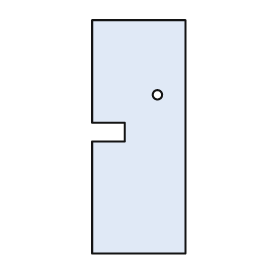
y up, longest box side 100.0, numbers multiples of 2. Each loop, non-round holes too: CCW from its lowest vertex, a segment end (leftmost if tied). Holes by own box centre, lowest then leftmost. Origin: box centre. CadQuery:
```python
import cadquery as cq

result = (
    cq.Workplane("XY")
    .moveTo(-20.0, -50.0)
    .lineTo(20.0, -50.0)
    .lineTo(20.0, 50.0)
    .lineTo(-20.0, 50.0)
    .lineTo(-20.0, 6.0)
    .lineTo(-6.0, 6.0)
    .lineTo(-6.0, -2.0)
    .lineTo(-20.0, -2.0)
    .close()
    .moveTo(8.0, 18.0)
    .circle(2.0)
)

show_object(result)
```